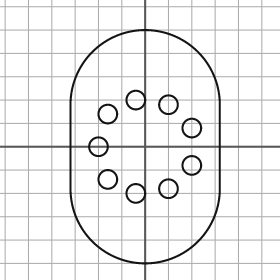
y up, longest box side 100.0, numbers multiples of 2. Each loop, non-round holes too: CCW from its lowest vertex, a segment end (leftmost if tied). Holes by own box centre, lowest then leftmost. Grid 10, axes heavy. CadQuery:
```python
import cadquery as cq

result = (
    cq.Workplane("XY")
    .moveTo(-32.0, -18.0)
    .threePointArc((0.0, -50.0), (32.0, -18.0))
    .lineTo(32.0, 18.0)
    .threePointArc((0.0, 50.0), (-32.0, 18.0))
    .close()
    .moveTo(-4.0, -20.0)
    .circle(4.0)
    .moveTo(10.0, -18.0)
    .circle(4.0)
    .moveTo(-16.0, -14.0)
    .circle(4.0)
    .moveTo(20.0, -8.0)
    .circle(4.0)
    .moveTo(-20.0, 0.0)
    .circle(4.0)
    .moveTo(20.0, 8.0)
    .circle(4.0)
    .moveTo(-16.0, 14.0)
    .circle(4.0)
    .moveTo(10.0, 18.0)
    .circle(4.0)
    .moveTo(-4.0, 20.0)
    .circle(4.0)
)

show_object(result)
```